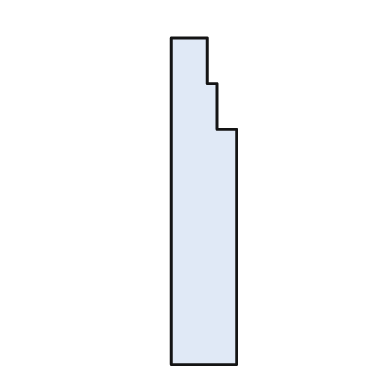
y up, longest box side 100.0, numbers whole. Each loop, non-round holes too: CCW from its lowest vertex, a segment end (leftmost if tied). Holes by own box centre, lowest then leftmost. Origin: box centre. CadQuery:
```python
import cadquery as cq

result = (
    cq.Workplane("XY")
    .moveTo(-10.0, -50.0)
    .lineTo(10.0, -50.0)
    .lineTo(10.0, 22.0)
    .lineTo(4.0, 22.0)
    .lineTo(4.0, 36.0)
    .lineTo(1.0, 36.0)
    .lineTo(1.0, 50.0)
    .lineTo(-10.0, 50.0)
    .close()
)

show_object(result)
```